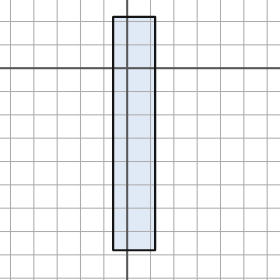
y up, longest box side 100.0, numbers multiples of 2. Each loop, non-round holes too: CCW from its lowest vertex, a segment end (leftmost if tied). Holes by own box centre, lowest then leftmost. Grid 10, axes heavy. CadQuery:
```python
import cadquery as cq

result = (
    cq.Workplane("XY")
    .moveTo(-6.0, -78.0)
    .lineTo(12.0, -78.0)
    .lineTo(12.0, 22.0)
    .lineTo(-6.0, 22.0)
    .close()
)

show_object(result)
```